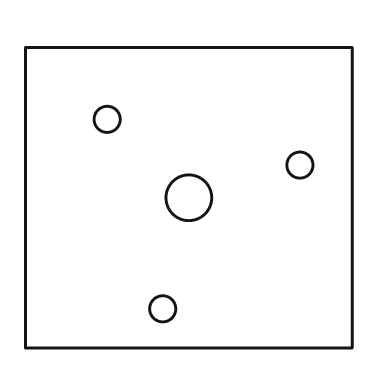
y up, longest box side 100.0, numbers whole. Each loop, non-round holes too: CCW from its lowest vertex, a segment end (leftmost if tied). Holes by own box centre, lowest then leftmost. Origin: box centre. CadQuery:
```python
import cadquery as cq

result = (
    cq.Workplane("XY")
    .moveTo(-50.0, -46.0)
    .lineTo(50.0, -46.0)
    .lineTo(50.0, 46.0)
    .lineTo(-50.0, 46.0)
    .close()
    .moveTo(-8.0, -34.0)
    .circle(4.0)
    .moveTo(0.0, 0.0)
    .circle(7.0)
    .moveTo(34.0, 10.0)
    .circle(4.0)
    .moveTo(-25.0, 24.0)
    .circle(4.0)
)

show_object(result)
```